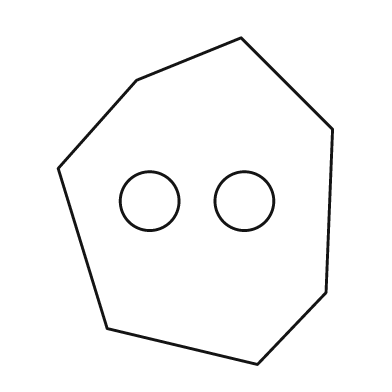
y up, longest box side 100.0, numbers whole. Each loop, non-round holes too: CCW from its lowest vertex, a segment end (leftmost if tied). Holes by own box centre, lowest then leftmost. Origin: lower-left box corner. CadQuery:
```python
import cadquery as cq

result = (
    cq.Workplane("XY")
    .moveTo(61.0, 0.0)
    .lineTo(82.0, 22.0)
    .lineTo(84.0, 72.0)
    .lineTo(56.0, 100.0)
    .lineTo(24.0, 87.0)
    .lineTo(0.0, 60.0)
    .lineTo(15.0, 11.0)
    .close()
    .moveTo(28.0, 50.0)
    .circle(9.0)
    .moveTo(57.0, 50.0)
    .circle(9.0)
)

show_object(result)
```